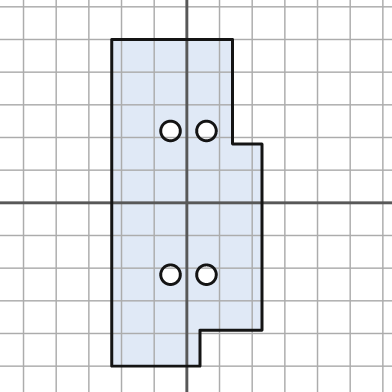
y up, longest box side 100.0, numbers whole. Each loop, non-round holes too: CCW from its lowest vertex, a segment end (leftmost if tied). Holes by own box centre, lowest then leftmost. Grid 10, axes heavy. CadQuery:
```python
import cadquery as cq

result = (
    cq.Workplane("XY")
    .moveTo(-23.0, -50.0)
    .lineTo(4.0, -50.0)
    .lineTo(4.0, -39.0)
    .lineTo(23.0, -39.0)
    .lineTo(23.0, 18.0)
    .lineTo(14.0, 18.0)
    .lineTo(14.0, 50.0)
    .lineTo(-23.0, 50.0)
    .close()
    .moveTo(-5.0, -22.0)
    .circle(3.0)
    .moveTo(6.0, -22.0)
    .circle(3.0)
    .moveTo(-5.0, 22.0)
    .circle(3.0)
    .moveTo(6.0, 22.0)
    .circle(3.0)
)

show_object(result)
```